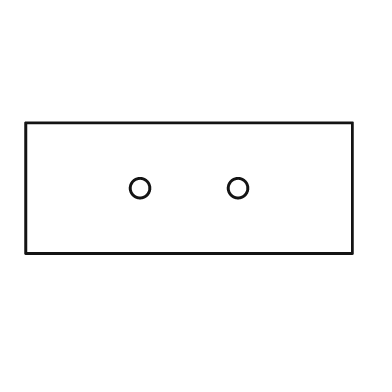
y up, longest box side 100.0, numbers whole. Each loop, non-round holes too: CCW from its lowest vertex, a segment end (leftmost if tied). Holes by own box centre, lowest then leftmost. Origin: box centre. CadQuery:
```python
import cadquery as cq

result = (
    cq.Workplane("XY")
    .moveTo(-50.0, -20.0)
    .lineTo(50.0, -20.0)
    .lineTo(50.0, 20.0)
    .lineTo(-50.0, 20.0)
    .close()
    .moveTo(-15.0, 0.0)
    .circle(3.0)
    .moveTo(15.0, 0.0)
    .circle(3.0)
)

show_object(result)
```